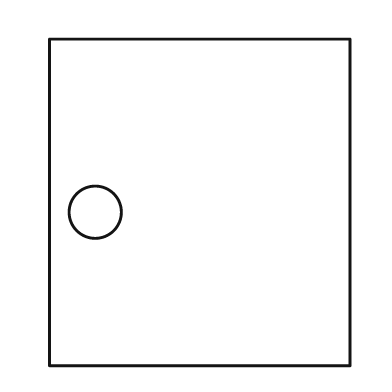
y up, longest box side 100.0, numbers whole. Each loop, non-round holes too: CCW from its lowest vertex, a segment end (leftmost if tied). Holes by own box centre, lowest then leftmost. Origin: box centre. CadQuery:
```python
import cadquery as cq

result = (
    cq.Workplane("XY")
    .moveTo(-46.0, -50.0)
    .lineTo(46.0, -50.0)
    .lineTo(46.0, 50.0)
    .lineTo(-46.0, 50.0)
    .close()
    .moveTo(-32.0, -3.0)
    .circle(8.0)
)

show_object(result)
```